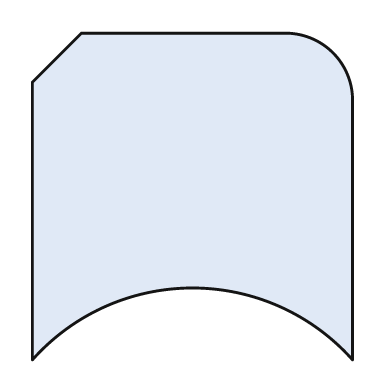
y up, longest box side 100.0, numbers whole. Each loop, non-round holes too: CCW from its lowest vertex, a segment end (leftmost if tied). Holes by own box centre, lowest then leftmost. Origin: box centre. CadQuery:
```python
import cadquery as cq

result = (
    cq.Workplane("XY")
    .moveTo(-49.0, -50.0)
    .threePointArc((0.0, -28.0), (49.0, -50.0))
    .lineTo(49.0, 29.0)
    .threePointArc((43.0, 44.0), (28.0, 50.0))
    .lineTo(-34.0, 50.0)
    .lineTo(-49.0, 35.0)
    .close()
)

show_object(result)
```